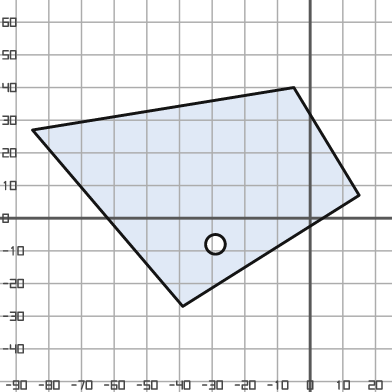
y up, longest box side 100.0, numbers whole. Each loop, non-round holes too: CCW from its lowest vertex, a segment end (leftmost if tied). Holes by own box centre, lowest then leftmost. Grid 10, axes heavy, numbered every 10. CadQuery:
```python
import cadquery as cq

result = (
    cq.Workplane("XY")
    .moveTo(-39.0, -27.0)
    .lineTo(15.0, 7.0)
    .lineTo(-5.0, 40.0)
    .lineTo(-85.0, 27.0)
    .close()
    .moveTo(-29.0, -8.0)
    .circle(3.0)
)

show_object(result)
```